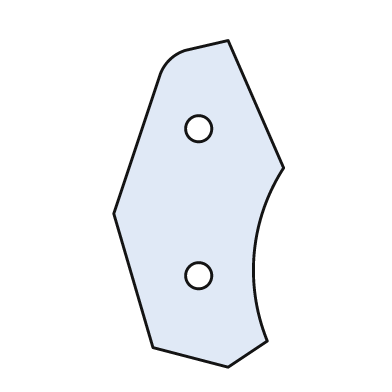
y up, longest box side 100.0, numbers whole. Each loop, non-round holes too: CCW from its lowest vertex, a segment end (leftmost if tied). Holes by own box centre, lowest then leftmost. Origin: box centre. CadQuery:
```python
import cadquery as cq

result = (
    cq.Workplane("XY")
    .moveTo(9.0, -50.0)
    .lineTo(21.0, -42.0)
    .threePointArc((17.0, -15.0), (26.0, 11.0))
    .lineTo(9.0, 50.0)
    .lineTo(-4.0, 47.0)
    .threePointArc((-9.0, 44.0), (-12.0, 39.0))
    .lineTo(-26.0, -3.0)
    .lineTo(-14.0, -44.0)
    .close()
    .moveTo(0.0, -22.0)
    .circle(4.0)
    .moveTo(0.0, 23.0)
    .circle(4.0)
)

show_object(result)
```